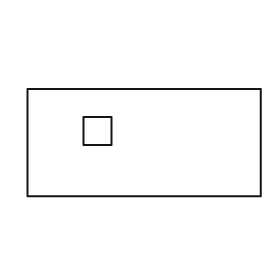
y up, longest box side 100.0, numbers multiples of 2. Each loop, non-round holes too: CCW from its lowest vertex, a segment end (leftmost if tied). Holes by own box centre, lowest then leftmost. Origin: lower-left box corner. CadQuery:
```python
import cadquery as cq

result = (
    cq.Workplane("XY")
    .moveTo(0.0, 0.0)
    .lineTo(100.0, 0.0)
    .lineTo(100.0, 46.0)
    .lineTo(0.0, 46.0)
    .close()
    .moveTo(24.0, 22.0)
    .lineTo(36.0, 22.0)
    .lineTo(36.0, 34.0)
    .lineTo(24.0, 34.0)
    .close()
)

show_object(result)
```